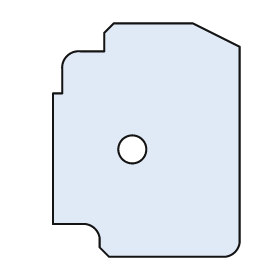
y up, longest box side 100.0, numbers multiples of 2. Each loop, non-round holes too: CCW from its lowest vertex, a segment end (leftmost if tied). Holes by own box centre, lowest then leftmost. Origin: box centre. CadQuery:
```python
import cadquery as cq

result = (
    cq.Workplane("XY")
    .moveTo(-16.0, -50.0)
    .lineTo(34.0, -50.0)
    .threePointArc((38.0, -48.0), (40.0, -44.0))
    .lineTo(40.0, 40.0)
    .lineTo(20.0, 50.0)
    .lineTo(-14.0, 50.0)
    .lineTo(-18.0, 46.0)
    .lineTo(-18.0, 38.0)
    .lineTo(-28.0, 38.0)
    .threePointArc((-34.0, 36.0), (-36.0, 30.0))
    .lineTo(-36.0, 20.0)
    .lineTo(-40.0, 20.0)
    .lineTo(-40.0, -36.0)
    .lineTo(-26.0, -36.0)
    .threePointArc((-22.0, -38.0), (-20.0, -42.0))
    .lineTo(-20.0, -46.0)
    .close()
    .moveTo(-6.0, -4.0)
    .circle(6.0)
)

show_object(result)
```